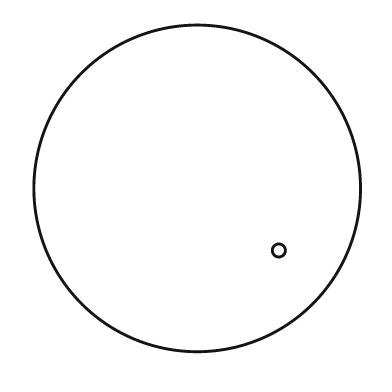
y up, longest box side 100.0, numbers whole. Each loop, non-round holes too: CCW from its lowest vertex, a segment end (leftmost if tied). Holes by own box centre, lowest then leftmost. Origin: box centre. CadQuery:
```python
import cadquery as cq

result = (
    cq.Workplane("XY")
    .moveTo(0.0, 0.0)
    .circle(50.0)
    .moveTo(25.0, -19.0)
    .circle(2.0)
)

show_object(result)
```